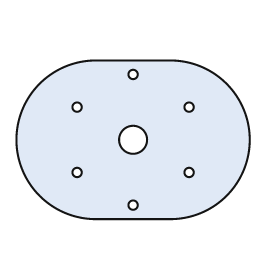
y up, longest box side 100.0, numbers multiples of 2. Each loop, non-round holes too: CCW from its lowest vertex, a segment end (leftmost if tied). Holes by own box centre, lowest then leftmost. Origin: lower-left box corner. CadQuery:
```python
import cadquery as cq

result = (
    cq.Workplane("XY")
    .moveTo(34.0, 0.0)
    .lineTo(66.0, 0.0)
    .threePointArc((100.0, 34.0), (66.0, 68.0))
    .lineTo(34.0, 68.0)
    .threePointArc((0.0, 34.0), (34.0, 0.0))
    .close()
    .moveTo(50.0, 6.0)
    .circle(2.0)
    .moveTo(26.0, 20.0)
    .circle(2.0)
    .moveTo(74.0, 20.0)
    .circle(2.0)
    .moveTo(50.0, 34.0)
    .circle(6.0)
    .moveTo(26.0, 48.0)
    .circle(2.0)
    .moveTo(74.0, 48.0)
    .circle(2.0)
    .moveTo(50.0, 62.0)
    .circle(2.0)
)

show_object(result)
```